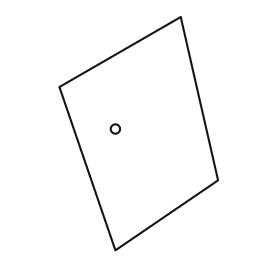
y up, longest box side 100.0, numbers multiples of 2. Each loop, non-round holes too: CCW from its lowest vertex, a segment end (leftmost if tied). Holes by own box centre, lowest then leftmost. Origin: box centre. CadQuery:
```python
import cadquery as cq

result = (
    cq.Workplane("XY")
    .moveTo(-10.0, -50.0)
    .lineTo(34.0, -20.0)
    .lineTo(18.0, 50.0)
    .lineTo(-34.0, 20.0)
    .close()
    .moveTo(-10.0, 2.0)
    .circle(2.0)
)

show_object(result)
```